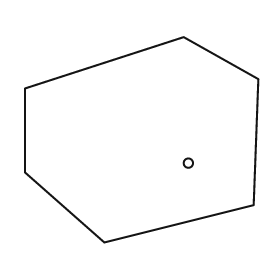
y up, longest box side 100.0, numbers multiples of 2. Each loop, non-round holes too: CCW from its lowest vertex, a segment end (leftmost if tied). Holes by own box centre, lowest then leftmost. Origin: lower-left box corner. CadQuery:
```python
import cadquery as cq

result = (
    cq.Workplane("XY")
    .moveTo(34.0, 0.0)
    .lineTo(98.0, 16.0)
    .lineTo(100.0, 70.0)
    .lineTo(68.0, 88.0)
    .lineTo(0.0, 66.0)
    .lineTo(0.0, 30.0)
    .close()
    .moveTo(70.0, 34.0)
    .circle(2.0)
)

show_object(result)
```